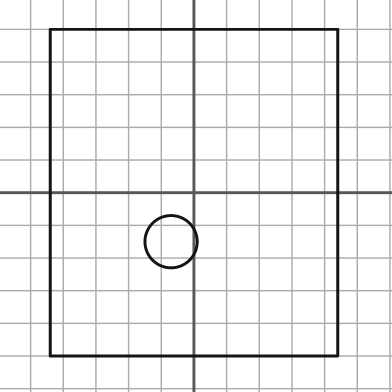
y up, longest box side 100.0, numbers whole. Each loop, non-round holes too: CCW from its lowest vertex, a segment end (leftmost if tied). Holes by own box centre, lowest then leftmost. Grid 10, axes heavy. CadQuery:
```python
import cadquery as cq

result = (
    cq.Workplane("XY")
    .moveTo(-44.0, -50.0)
    .lineTo(44.0, -50.0)
    .lineTo(44.0, 50.0)
    .lineTo(-44.0, 50.0)
    .close()
    .moveTo(-7.0, -15.0)
    .circle(8.0)
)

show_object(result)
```